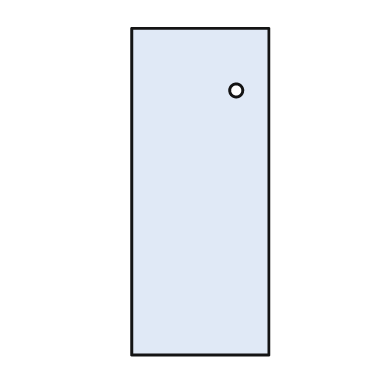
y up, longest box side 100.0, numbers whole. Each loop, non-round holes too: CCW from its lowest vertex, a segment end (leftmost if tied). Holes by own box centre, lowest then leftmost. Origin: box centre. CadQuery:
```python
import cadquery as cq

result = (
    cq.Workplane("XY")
    .moveTo(-21.0, -50.0)
    .lineTo(21.0, -50.0)
    .lineTo(21.0, 50.0)
    .lineTo(-21.0, 50.0)
    .close()
    .moveTo(11.0, 31.0)
    .circle(2.0)
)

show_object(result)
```